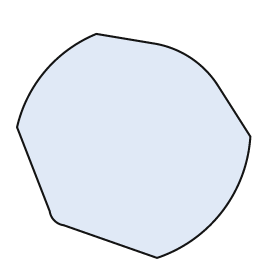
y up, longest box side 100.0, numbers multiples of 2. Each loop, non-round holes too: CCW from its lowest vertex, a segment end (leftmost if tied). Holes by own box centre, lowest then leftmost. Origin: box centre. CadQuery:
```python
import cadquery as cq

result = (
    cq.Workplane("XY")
    .moveTo(10.0, -48.0)
    .threePointArc((38.0, -28.0), (50.0, 4.0))
    .lineTo(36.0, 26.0)
    .threePointArc((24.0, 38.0), (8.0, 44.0))
    .lineTo(-16.0, 48.0)
    .threePointArc((-38.0, 32.0), (-50.0, 8.0))
    .lineTo(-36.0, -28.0)
    .threePointArc((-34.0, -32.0), (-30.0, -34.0))
    .close()
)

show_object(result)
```